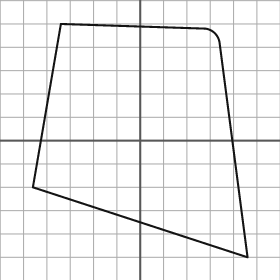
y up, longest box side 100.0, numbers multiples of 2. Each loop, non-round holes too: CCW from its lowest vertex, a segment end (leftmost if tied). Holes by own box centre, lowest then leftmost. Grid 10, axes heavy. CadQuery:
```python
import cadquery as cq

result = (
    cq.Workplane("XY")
    .moveTo(46.0, -50.0)
    .lineTo(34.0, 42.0)
    .threePointArc((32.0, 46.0), (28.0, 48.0))
    .lineTo(-34.0, 50.0)
    .lineTo(-46.0, -20.0)
    .close()
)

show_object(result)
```